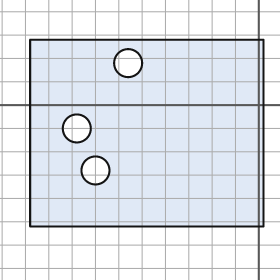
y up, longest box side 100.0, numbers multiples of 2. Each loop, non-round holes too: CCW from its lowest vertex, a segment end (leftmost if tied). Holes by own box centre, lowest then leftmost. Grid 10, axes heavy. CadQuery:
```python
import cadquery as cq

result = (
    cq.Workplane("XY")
    .moveTo(-98.0, -52.0)
    .lineTo(2.0, -52.0)
    .lineTo(2.0, 28.0)
    .lineTo(-98.0, 28.0)
    .close()
    .moveTo(-70.0, -28.0)
    .circle(6.0)
    .moveTo(-78.0, -10.0)
    .circle(6.0)
    .moveTo(-56.0, 18.0)
    .circle(6.0)
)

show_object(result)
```